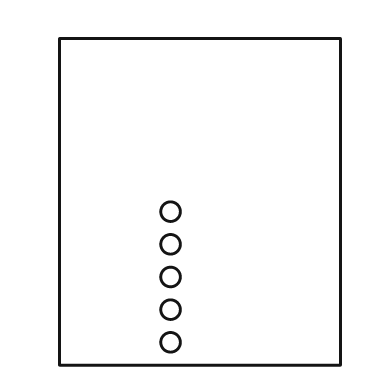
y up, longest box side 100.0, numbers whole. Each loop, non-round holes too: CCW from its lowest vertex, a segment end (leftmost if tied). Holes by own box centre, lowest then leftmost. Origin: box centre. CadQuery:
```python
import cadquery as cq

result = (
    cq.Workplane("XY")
    .moveTo(-43.0, -50.0)
    .lineTo(43.0, -50.0)
    .lineTo(43.0, 50.0)
    .lineTo(-43.0, 50.0)
    .close()
    .moveTo(-9.0, -43.0)
    .circle(3.0)
    .moveTo(-9.0, -33.0)
    .circle(3.0)
    .moveTo(-9.0, -23.0)
    .circle(3.0)
    .moveTo(-9.0, -13.0)
    .circle(3.0)
    .moveTo(-9.0, -3.0)
    .circle(3.0)
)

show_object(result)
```